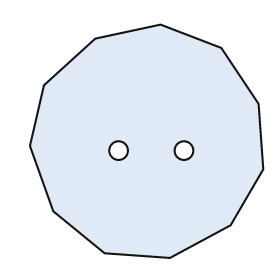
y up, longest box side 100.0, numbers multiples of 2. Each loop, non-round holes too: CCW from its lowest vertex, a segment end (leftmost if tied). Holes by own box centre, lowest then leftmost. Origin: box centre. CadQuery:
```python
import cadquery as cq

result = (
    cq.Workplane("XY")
    .moveTo(10.0, -50.0)
    .lineTo(36.0, -36.0)
    .lineTo(50.0, -12.0)
    .lineTo(48.0, 16.0)
    .lineTo(32.0, 40.0)
    .lineTo(6.0, 50.0)
    .lineTo(-22.0, 44.0)
    .lineTo(-44.0, 24.0)
    .lineTo(-50.0, -2.0)
    .lineTo(-40.0, -30.0)
    .lineTo(-18.0, -48.0)
    .close()
    .moveTo(-12.0, -4.0)
    .circle(4.0)
    .moveTo(16.0, -4.0)
    .circle(4.0)
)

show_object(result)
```